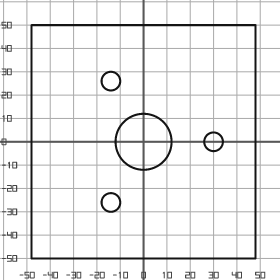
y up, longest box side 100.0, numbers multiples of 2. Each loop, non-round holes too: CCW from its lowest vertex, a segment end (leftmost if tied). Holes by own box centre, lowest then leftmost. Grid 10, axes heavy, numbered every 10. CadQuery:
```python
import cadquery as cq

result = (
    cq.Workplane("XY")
    .moveTo(-48.0, -50.0)
    .lineTo(48.0, -50.0)
    .lineTo(48.0, 50.0)
    .lineTo(-48.0, 50.0)
    .close()
    .moveTo(-14.0, -26.0)
    .circle(4.0)
    .moveTo(0.0, 0.0)
    .circle(12.0)
    .moveTo(30.0, 0.0)
    .circle(4.0)
    .moveTo(-14.0, 26.0)
    .circle(4.0)
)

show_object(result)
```